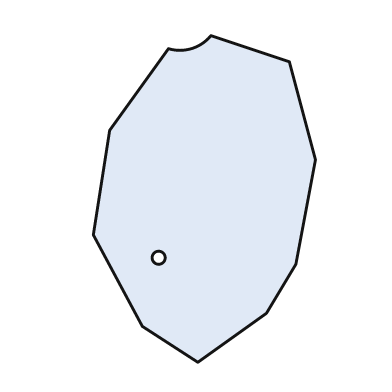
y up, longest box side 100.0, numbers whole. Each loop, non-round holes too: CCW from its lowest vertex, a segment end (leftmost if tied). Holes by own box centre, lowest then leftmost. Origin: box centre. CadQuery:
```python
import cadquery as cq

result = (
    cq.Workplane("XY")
    .moveTo(-2.0, -50.0)
    .lineTo(19.0, -35.0)
    .lineTo(28.0, -20.0)
    .lineTo(34.0, 12.0)
    .lineTo(26.0, 42.0)
    .lineTo(2.0, 50.0)
    .threePointArc((-4.0, 46.0), (-11.0, 46.0))
    .lineTo(-29.0, 21.0)
    .lineTo(-34.0, -11.0)
    .lineTo(-19.0, -39.0)
    .close()
    .moveTo(-14.0, -18.0)
    .circle(2.0)
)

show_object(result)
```